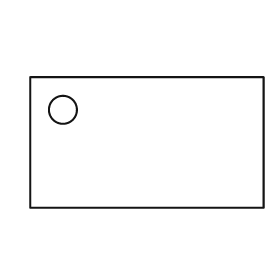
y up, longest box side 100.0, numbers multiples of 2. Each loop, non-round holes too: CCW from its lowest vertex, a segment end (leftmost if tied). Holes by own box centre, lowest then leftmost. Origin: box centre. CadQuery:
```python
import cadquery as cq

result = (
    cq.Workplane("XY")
    .moveTo(-50.0, -28.0)
    .lineTo(50.0, -28.0)
    .lineTo(50.0, 28.0)
    .lineTo(-50.0, 28.0)
    .close()
    .moveTo(-36.0, 14.0)
    .circle(6.0)
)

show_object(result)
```